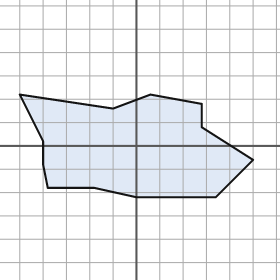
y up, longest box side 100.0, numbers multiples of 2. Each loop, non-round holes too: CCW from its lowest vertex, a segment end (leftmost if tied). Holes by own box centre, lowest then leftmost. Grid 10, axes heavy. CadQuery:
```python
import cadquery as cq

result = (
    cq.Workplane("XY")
    .moveTo(0.0, -22.0)
    .lineTo(34.0, -22.0)
    .lineTo(50.0, -6.0)
    .lineTo(28.0, 8.0)
    .lineTo(28.0, 18.0)
    .lineTo(6.0, 22.0)
    .lineTo(-10.0, 16.0)
    .lineTo(-50.0, 22.0)
    .lineTo(-40.0, 2.0)
    .lineTo(-40.0, -8.0)
    .lineTo(-38.0, -18.0)
    .lineTo(-18.0, -18.0)
    .close()
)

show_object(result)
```